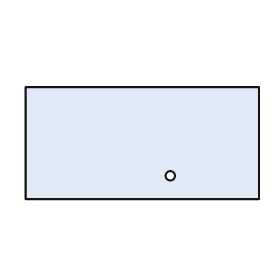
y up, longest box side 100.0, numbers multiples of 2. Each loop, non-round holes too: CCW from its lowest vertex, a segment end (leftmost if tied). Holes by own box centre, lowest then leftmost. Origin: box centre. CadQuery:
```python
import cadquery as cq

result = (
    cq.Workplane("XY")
    .moveTo(-50.0, -24.0)
    .lineTo(50.0, -24.0)
    .lineTo(50.0, 24.0)
    .lineTo(-50.0, 24.0)
    .close()
    .moveTo(12.0, -14.0)
    .circle(2.0)
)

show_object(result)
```